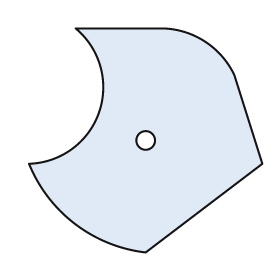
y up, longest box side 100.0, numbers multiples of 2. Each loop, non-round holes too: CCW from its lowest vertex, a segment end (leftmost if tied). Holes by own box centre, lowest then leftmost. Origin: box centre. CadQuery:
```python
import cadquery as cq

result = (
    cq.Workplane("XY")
    .moveTo(0.0, -48.0)
    .lineTo(50.0, -10.0)
    .lineTo(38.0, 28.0)
    .threePointArc((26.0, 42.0), (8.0, 48.0))
    .lineTo(-30.0, 48.0)
    .threePointArc((-20.0, 12.0), (-50.0, -10.0))
    .threePointArc((-30.0, -36.0), (0.0, -48.0))
    .close()
    .moveTo(0.0, 0.0)
    .circle(4.0)
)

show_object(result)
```